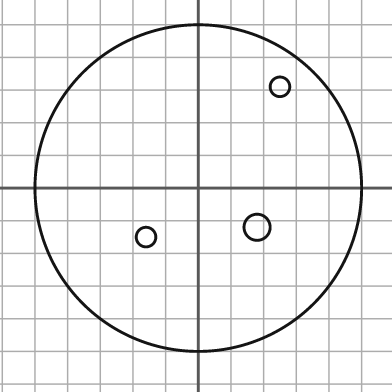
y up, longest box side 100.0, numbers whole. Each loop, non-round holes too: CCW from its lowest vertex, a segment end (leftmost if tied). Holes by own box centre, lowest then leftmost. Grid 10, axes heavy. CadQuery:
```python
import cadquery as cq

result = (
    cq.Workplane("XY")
    .moveTo(0.0, 0.0)
    .circle(50.0)
    .moveTo(-16.0, -15.0)
    .circle(3.0)
    .moveTo(18.0, -12.0)
    .circle(4.0)
    .moveTo(25.0, 31.0)
    .circle(3.0)
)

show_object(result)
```